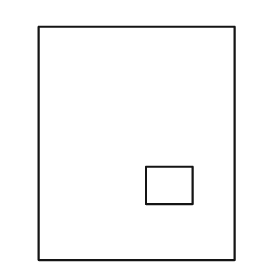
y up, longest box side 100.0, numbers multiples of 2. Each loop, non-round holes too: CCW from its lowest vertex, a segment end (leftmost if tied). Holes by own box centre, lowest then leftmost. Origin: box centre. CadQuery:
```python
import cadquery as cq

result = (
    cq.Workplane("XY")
    .moveTo(-42.0, -50.0)
    .lineTo(42.0, -50.0)
    .lineTo(42.0, 50.0)
    .lineTo(-42.0, 50.0)
    .close()
    .moveTo(4.0, -26.0)
    .lineTo(24.0, -26.0)
    .lineTo(24.0, -10.0)
    .lineTo(4.0, -10.0)
    .close()
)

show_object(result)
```